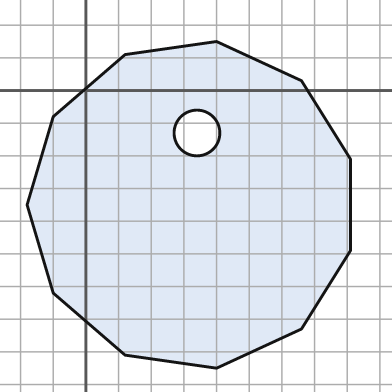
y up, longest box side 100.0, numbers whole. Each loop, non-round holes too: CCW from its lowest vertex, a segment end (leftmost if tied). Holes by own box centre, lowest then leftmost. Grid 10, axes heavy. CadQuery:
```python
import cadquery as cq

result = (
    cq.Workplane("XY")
    .moveTo(40.0, -85.0)
    .lineTo(66.0, -73.0)
    .lineTo(81.0, -49.0)
    .lineTo(81.0, -21.0)
    .lineTo(66.0, 3.0)
    .lineTo(40.0, 15.0)
    .lineTo(12.0, 11.0)
    .lineTo(-10.0, -8.0)
    .lineTo(-18.0, -35.0)
    .lineTo(-10.0, -62.0)
    .lineTo(12.0, -81.0)
    .close()
    .moveTo(34.0, -13.0)
    .circle(7.0)
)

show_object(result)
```